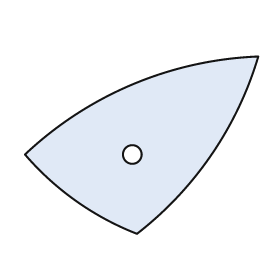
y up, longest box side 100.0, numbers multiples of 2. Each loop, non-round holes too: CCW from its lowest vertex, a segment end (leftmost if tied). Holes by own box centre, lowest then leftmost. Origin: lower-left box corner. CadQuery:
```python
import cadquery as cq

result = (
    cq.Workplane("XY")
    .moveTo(48.0, 0.0)
    .threePointArc((80.0, 34.0), (100.0, 76.0))
    .threePointArc((46.0, 64.0), (0.0, 34.0))
    .threePointArc((22.0, 14.0), (48.0, 0.0))
    .close()
    .moveTo(46.0, 34.0)
    .circle(4.0)
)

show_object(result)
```